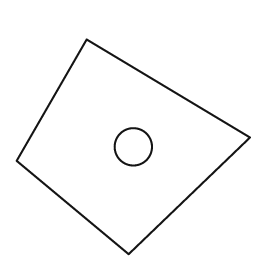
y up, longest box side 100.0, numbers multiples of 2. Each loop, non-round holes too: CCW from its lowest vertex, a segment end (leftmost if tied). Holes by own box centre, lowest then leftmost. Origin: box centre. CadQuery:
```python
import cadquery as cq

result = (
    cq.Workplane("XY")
    .moveTo(-2.0, -46.0)
    .lineTo(50.0, 4.0)
    .lineTo(-20.0, 46.0)
    .lineTo(-50.0, -6.0)
    .close()
    .moveTo(0.0, 0.0)
    .circle(8.0)
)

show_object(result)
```